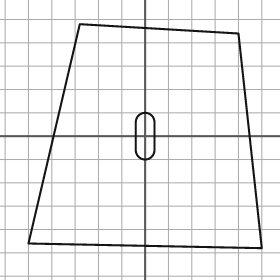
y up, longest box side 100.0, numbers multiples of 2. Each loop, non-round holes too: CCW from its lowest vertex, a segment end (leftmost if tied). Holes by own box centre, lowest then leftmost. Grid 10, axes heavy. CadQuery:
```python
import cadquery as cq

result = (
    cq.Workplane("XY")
    .moveTo(50.0, -48.0)
    .lineTo(40.0, 44.0)
    .lineTo(-28.0, 48.0)
    .lineTo(-50.0, -46.0)
    .close()
    .moveTo(-4.0, -6.0)
    .threePointArc((0.0, -10.0), (4.0, -6.0))
    .lineTo(4.0, 6.0)
    .threePointArc((0.0, 10.0), (-4.0, 6.0))
    .close()
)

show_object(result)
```